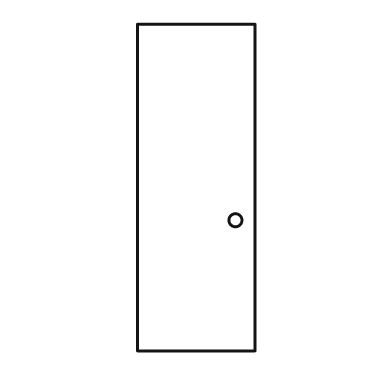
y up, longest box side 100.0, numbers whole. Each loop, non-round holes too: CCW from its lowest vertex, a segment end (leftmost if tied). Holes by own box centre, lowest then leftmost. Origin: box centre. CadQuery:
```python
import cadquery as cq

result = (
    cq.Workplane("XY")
    .moveTo(-18.0, -50.0)
    .lineTo(18.0, -50.0)
    .lineTo(18.0, 50.0)
    .lineTo(-18.0, 50.0)
    .close()
    .moveTo(12.0, -10.0)
    .circle(2.0)
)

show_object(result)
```